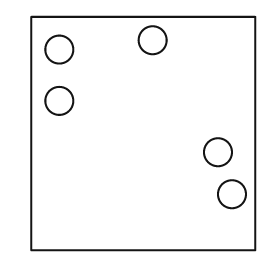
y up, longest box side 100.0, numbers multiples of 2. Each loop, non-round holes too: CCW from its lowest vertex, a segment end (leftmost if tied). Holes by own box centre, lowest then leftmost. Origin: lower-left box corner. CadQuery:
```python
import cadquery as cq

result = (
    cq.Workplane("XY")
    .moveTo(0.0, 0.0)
    .lineTo(96.0, 0.0)
    .lineTo(96.0, 100.0)
    .lineTo(0.0, 100.0)
    .close()
    .moveTo(86.0, 24.0)
    .circle(6.0)
    .moveTo(80.0, 42.0)
    .circle(6.0)
    .moveTo(12.0, 64.0)
    .circle(6.0)
    .moveTo(12.0, 86.0)
    .circle(6.0)
    .moveTo(52.0, 90.0)
    .circle(6.0)
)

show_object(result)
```